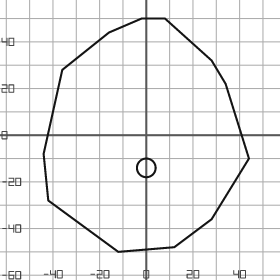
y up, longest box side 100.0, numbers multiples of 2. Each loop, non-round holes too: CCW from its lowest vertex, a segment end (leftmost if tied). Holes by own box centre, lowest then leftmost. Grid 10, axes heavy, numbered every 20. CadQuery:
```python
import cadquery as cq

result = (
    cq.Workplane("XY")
    .moveTo(-12.0, -50.0)
    .lineTo(12.0, -48.0)
    .lineTo(28.0, -36.0)
    .lineTo(44.0, -10.0)
    .lineTo(34.0, 22.0)
    .lineTo(28.0, 32.0)
    .lineTo(8.0, 50.0)
    .lineTo(-2.0, 50.0)
    .lineTo(-16.0, 44.0)
    .lineTo(-36.0, 28.0)
    .lineTo(-44.0, -8.0)
    .lineTo(-42.0, -28.0)
    .close()
    .moveTo(0.0, -14.0)
    .circle(4.0)
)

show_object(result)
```